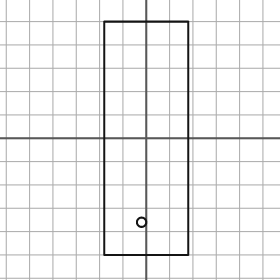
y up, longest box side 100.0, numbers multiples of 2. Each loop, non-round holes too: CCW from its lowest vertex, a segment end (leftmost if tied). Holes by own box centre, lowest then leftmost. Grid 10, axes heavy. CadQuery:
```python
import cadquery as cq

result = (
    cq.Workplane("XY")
    .moveTo(-18.0, -50.0)
    .lineTo(18.0, -50.0)
    .lineTo(18.0, 50.0)
    .lineTo(-18.0, 50.0)
    .close()
    .moveTo(-2.0, -36.0)
    .circle(2.0)
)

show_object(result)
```